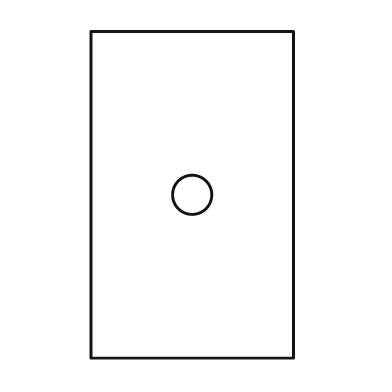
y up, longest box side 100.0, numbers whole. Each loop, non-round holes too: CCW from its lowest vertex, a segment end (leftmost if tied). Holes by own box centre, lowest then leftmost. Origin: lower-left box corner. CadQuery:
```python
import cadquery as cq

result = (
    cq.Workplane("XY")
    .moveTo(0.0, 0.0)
    .lineTo(62.0, 0.0)
    .lineTo(62.0, 100.0)
    .lineTo(0.0, 100.0)
    .close()
    .moveTo(31.0, 50.0)
    .circle(6.0)
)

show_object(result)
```